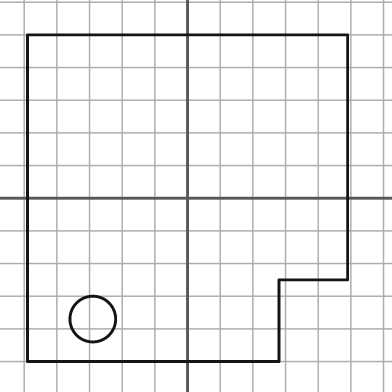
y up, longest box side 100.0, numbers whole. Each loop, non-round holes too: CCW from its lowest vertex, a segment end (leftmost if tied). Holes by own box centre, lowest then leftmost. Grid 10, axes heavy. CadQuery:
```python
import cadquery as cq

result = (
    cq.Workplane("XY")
    .moveTo(-49.0, -50.0)
    .lineTo(28.0, -50.0)
    .lineTo(28.0, -25.0)
    .lineTo(49.0, -25.0)
    .lineTo(49.0, 50.0)
    .lineTo(-49.0, 50.0)
    .close()
    .moveTo(-29.0, -37.0)
    .circle(7.0)
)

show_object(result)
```